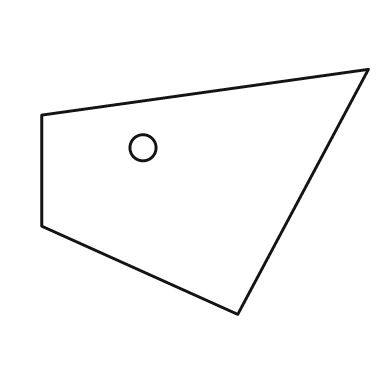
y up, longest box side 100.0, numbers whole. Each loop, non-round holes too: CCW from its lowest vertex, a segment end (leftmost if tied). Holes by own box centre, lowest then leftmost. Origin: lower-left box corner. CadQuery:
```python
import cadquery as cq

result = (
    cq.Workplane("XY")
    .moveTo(60.0, 0.0)
    .lineTo(100.0, 75.0)
    .lineTo(0.0, 61.0)
    .lineTo(0.0, 27.0)
    .close()
    .moveTo(31.0, 51.0)
    .circle(4.0)
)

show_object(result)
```